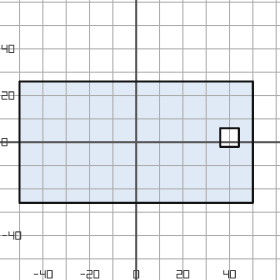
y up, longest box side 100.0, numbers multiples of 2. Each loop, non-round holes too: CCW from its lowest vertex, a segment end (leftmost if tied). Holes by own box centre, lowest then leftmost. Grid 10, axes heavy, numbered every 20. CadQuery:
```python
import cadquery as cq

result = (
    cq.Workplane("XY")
    .moveTo(-50.0, -26.0)
    .lineTo(50.0, -26.0)
    .lineTo(50.0, 26.0)
    .lineTo(-50.0, 26.0)
    .close()
    .moveTo(36.0, -2.0)
    .lineTo(44.0, -2.0)
    .lineTo(44.0, 6.0)
    .lineTo(36.0, 6.0)
    .close()
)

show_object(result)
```